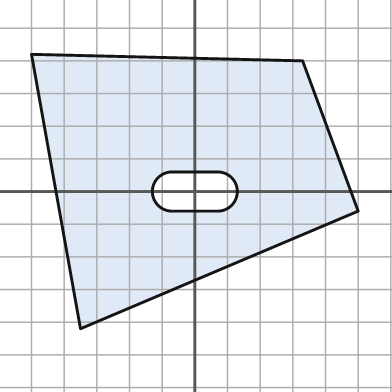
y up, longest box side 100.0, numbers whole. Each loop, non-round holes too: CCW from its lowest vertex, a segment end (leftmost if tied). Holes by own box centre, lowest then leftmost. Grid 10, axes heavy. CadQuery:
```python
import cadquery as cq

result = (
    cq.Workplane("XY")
    .moveTo(-35.0, -42.0)
    .lineTo(50.0, -6.0)
    .lineTo(33.0, 40.0)
    .lineTo(-50.0, 42.0)
    .close()
    .moveTo(-7.0, -6.0)
    .lineTo(7.0, -6.0)
    .threePointArc((13.0, 0.0), (7.0, 6.0))
    .lineTo(-7.0, 6.0)
    .threePointArc((-13.0, 0.0), (-7.0, -6.0))
    .close()
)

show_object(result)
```